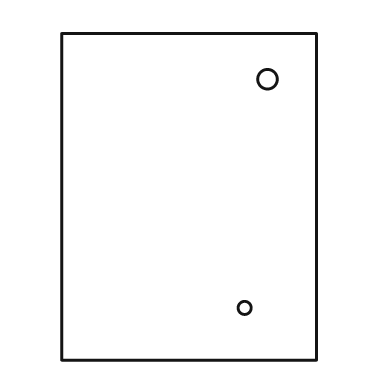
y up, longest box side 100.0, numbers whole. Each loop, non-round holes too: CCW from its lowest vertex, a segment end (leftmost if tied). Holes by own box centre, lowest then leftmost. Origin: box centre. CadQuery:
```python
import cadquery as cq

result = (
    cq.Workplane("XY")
    .moveTo(-39.0, -50.0)
    .lineTo(39.0, -50.0)
    .lineTo(39.0, 50.0)
    .lineTo(-39.0, 50.0)
    .close()
    .moveTo(17.0, -34.0)
    .circle(2.0)
    .moveTo(24.0, 36.0)
    .circle(3.0)
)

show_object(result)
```